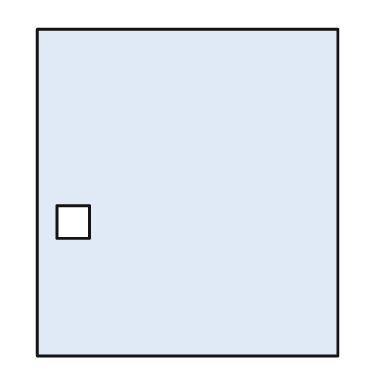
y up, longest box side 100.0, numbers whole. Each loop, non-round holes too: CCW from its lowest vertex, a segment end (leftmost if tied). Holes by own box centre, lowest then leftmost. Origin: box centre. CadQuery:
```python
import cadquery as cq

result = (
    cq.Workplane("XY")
    .moveTo(-46.0, -50.0)
    .lineTo(46.0, -50.0)
    .lineTo(46.0, 50.0)
    .lineTo(-46.0, 50.0)
    .close()
    .moveTo(-40.0, -14.0)
    .lineTo(-30.0, -14.0)
    .lineTo(-30.0, -4.0)
    .lineTo(-40.0, -4.0)
    .close()
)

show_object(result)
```